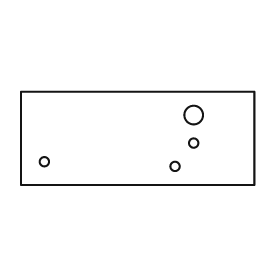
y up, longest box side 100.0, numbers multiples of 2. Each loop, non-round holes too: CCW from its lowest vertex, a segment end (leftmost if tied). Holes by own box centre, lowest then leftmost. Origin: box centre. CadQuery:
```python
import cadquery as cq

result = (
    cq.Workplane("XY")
    .moveTo(-50.0, -20.0)
    .lineTo(50.0, -20.0)
    .lineTo(50.0, 20.0)
    .lineTo(-50.0, 20.0)
    .close()
    .moveTo(16.0, -12.0)
    .circle(2.0)
    .moveTo(-40.0, -10.0)
    .circle(2.0)
    .moveTo(24.0, -2.0)
    .circle(2.0)
    .moveTo(24.0, 10.0)
    .circle(4.0)
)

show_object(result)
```